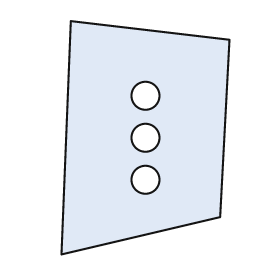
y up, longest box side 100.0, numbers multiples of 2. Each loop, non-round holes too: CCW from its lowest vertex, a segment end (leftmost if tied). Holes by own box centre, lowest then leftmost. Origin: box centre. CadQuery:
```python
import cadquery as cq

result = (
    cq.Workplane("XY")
    .moveTo(-36.0, -50.0)
    .lineTo(32.0, -34.0)
    .lineTo(36.0, 42.0)
    .lineTo(-32.0, 50.0)
    .close()
    .moveTo(0.0, -18.0)
    .circle(6.0)
    .moveTo(0.0, 0.0)
    .circle(6.0)
    .moveTo(0.0, 18.0)
    .circle(6.0)
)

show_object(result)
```